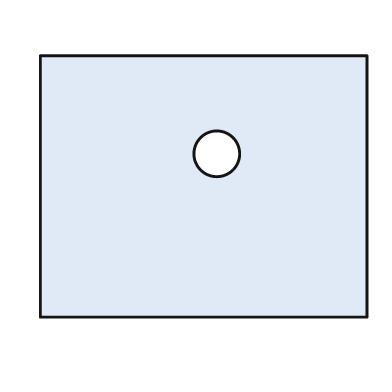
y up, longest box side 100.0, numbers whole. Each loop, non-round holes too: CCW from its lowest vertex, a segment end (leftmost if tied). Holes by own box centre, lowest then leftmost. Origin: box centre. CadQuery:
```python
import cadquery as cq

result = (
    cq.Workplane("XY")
    .moveTo(-50.0, -40.0)
    .lineTo(50.0, -40.0)
    .lineTo(50.0, 40.0)
    .lineTo(-50.0, 40.0)
    .close()
    .moveTo(4.0, 10.0)
    .circle(7.0)
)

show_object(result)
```